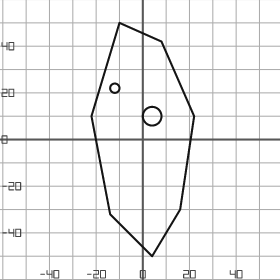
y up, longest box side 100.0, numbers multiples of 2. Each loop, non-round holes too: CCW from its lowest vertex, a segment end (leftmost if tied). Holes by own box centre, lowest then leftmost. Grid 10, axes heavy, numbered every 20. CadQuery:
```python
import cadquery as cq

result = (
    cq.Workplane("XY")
    .moveTo(4.0, -50.0)
    .lineTo(16.0, -30.0)
    .lineTo(22.0, 10.0)
    .lineTo(8.0, 42.0)
    .lineTo(-10.0, 50.0)
    .lineTo(-22.0, 10.0)
    .lineTo(-14.0, -32.0)
    .close()
    .moveTo(4.0, 10.0)
    .circle(4.0)
    .moveTo(-12.0, 22.0)
    .circle(2.0)
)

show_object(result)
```